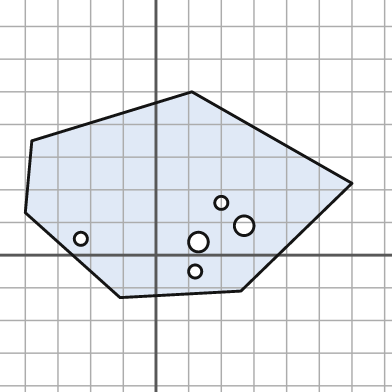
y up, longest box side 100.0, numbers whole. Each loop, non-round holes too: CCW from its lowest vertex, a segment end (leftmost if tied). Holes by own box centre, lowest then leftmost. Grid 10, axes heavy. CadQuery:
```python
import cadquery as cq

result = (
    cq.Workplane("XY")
    .moveTo(-11.0, -13.0)
    .lineTo(26.0, -11.0)
    .lineTo(60.0, 22.0)
    .lineTo(11.0, 50.0)
    .lineTo(-38.0, 35.0)
    .lineTo(-40.0, 13.0)
    .close()
    .moveTo(12.0, -5.0)
    .circle(2.0)
    .moveTo(13.0, 4.0)
    .circle(3.0)
    .moveTo(-23.0, 5.0)
    .circle(2.0)
    .moveTo(27.0, 9.0)
    .circle(3.0)
    .moveTo(20.0, 16.0)
    .circle(2.0)
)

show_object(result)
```